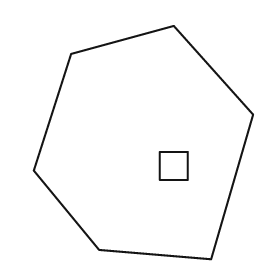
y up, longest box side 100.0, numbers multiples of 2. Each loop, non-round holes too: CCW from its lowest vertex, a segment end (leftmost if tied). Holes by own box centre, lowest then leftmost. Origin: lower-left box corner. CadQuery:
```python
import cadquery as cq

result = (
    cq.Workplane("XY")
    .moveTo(76.0, 0.0)
    .lineTo(94.0, 62.0)
    .lineTo(60.0, 100.0)
    .lineTo(16.0, 88.0)
    .lineTo(0.0, 38.0)
    .lineTo(28.0, 4.0)
    .close()
    .moveTo(54.0, 34.0)
    .lineTo(66.0, 34.0)
    .lineTo(66.0, 46.0)
    .lineTo(54.0, 46.0)
    .close()
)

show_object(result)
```